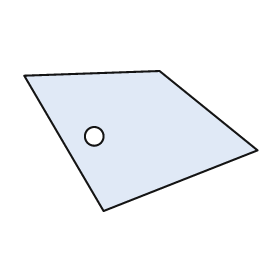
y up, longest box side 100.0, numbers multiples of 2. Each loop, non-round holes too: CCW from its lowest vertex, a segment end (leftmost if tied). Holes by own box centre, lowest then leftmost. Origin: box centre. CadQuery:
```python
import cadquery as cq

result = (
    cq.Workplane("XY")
    .moveTo(-16.0, -30.0)
    .lineTo(50.0, -4.0)
    .lineTo(8.0, 30.0)
    .lineTo(-50.0, 28.0)
    .close()
    .moveTo(-20.0, 2.0)
    .circle(4.0)
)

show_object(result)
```